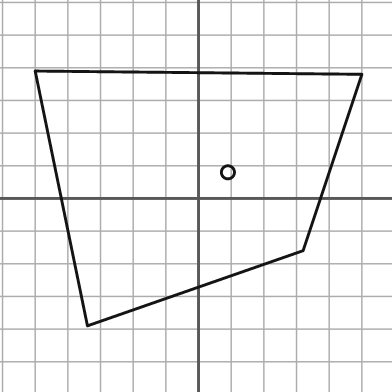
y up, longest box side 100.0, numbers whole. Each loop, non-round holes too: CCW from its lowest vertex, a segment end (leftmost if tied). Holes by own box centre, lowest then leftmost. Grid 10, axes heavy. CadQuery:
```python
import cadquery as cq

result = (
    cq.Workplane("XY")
    .moveTo(-34.0, -39.0)
    .lineTo(32.0, -16.0)
    .lineTo(50.0, 38.0)
    .lineTo(-50.0, 39.0)
    .close()
    .moveTo(9.0, 8.0)
    .circle(2.0)
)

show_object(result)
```